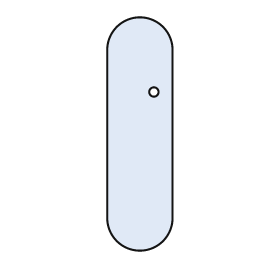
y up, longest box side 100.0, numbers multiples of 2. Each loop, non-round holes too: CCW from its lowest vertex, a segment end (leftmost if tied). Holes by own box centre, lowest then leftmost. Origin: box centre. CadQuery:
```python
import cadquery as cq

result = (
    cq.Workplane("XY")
    .moveTo(-14.0, -36.0)
    .threePointArc((0.0, -50.0), (14.0, -36.0))
    .lineTo(14.0, 36.0)
    .threePointArc((0.0, 50.0), (-14.0, 36.0))
    .close()
    .moveTo(6.0, 18.0)
    .circle(2.0)
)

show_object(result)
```